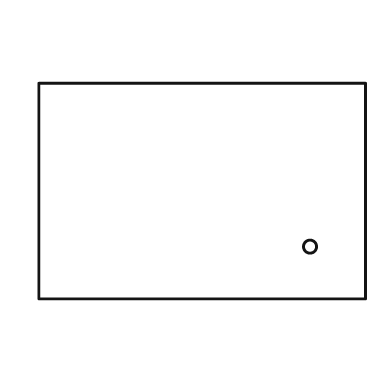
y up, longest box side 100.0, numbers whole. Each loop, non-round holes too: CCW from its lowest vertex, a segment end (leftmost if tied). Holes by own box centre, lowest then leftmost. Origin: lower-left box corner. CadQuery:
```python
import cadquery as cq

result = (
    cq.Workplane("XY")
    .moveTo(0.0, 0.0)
    .lineTo(100.0, 0.0)
    .lineTo(100.0, 66.0)
    .lineTo(0.0, 66.0)
    .close()
    .moveTo(83.0, 16.0)
    .circle(2.0)
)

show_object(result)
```